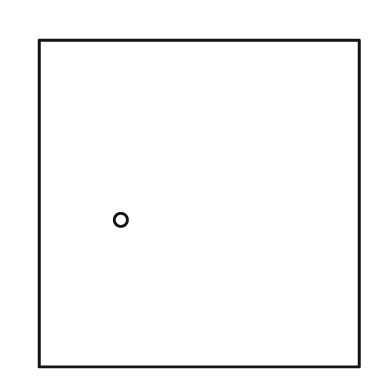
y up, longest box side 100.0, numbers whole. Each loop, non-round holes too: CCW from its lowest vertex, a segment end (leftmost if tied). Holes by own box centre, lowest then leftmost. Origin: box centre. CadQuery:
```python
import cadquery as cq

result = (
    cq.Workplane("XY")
    .moveTo(-49.0, -50.0)
    .lineTo(49.0, -50.0)
    .lineTo(49.0, 50.0)
    .lineTo(-49.0, 50.0)
    .close()
    .moveTo(-24.0, -5.0)
    .circle(2.0)
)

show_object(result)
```